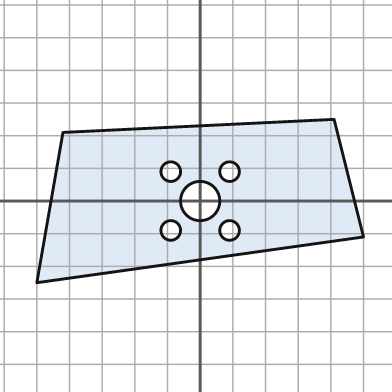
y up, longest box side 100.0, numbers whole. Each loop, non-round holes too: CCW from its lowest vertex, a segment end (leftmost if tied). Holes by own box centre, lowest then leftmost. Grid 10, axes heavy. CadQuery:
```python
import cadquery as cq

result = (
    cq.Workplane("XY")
    .moveTo(-50.0, -25.0)
    .lineTo(50.0, -11.0)
    .lineTo(41.0, 25.0)
    .lineTo(-42.0, 21.0)
    .close()
    .moveTo(-9.0, -9.0)
    .circle(3.0)
    .moveTo(9.0, -9.0)
    .circle(3.0)
    .moveTo(0.0, 0.0)
    .circle(6.0)
    .moveTo(-9.0, 9.0)
    .circle(3.0)
    .moveTo(9.0, 9.0)
    .circle(3.0)
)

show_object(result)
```